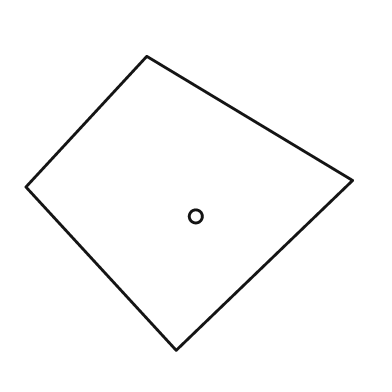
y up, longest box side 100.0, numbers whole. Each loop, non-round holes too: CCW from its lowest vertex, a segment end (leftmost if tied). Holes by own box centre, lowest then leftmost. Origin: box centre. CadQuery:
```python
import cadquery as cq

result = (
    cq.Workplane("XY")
    .moveTo(-4.0, -45.0)
    .lineTo(50.0, 7.0)
    .lineTo(-13.0, 45.0)
    .lineTo(-50.0, 5.0)
    .close()
    .moveTo(2.0, -4.0)
    .circle(2.0)
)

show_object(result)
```